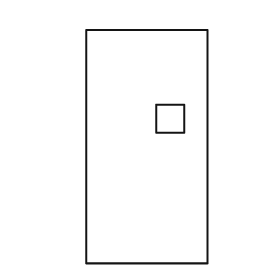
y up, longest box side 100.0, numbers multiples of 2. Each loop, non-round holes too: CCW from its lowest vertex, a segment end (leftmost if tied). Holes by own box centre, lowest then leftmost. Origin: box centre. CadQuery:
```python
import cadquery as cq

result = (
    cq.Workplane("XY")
    .moveTo(-26.0, -50.0)
    .lineTo(26.0, -50.0)
    .lineTo(26.0, 50.0)
    .lineTo(-26.0, 50.0)
    .close()
    .moveTo(4.0, 6.0)
    .lineTo(16.0, 6.0)
    .lineTo(16.0, 18.0)
    .lineTo(4.0, 18.0)
    .close()
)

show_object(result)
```